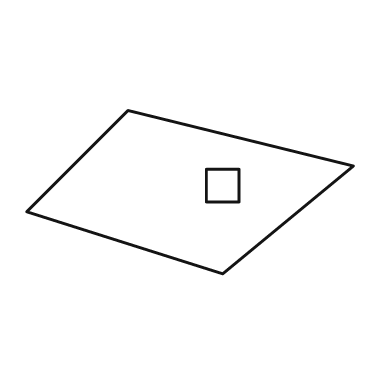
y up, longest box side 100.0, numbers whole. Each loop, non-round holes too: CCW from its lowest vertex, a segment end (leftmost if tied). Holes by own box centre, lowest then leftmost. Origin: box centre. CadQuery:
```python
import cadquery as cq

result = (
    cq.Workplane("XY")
    .moveTo(10.0, -25.0)
    .lineTo(50.0, 8.0)
    .lineTo(-19.0, 25.0)
    .lineTo(-50.0, -6.0)
    .close()
    .moveTo(5.0, -3.0)
    .lineTo(15.0, -3.0)
    .lineTo(15.0, 7.0)
    .lineTo(5.0, 7.0)
    .close()
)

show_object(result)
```